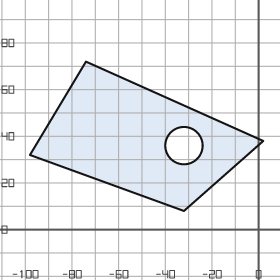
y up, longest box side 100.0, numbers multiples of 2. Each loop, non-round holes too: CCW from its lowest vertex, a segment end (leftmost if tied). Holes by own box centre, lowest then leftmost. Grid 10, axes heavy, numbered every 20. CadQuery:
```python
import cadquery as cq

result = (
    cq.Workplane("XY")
    .moveTo(-32.0, 8.0)
    .lineTo(2.0, 38.0)
    .lineTo(-74.0, 72.0)
    .lineTo(-98.0, 32.0)
    .close()
    .moveTo(-32.0, 36.0)
    .circle(8.0)
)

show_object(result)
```